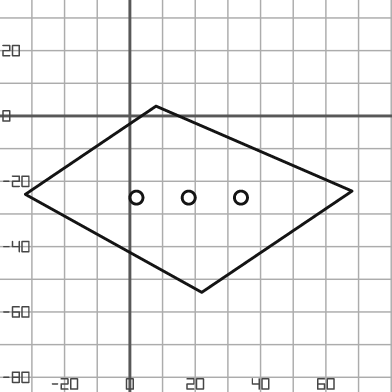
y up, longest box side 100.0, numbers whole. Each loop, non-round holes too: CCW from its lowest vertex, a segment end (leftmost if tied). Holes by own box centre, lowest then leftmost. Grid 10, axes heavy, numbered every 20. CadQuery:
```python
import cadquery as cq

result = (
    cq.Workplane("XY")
    .moveTo(22.0, -54.0)
    .lineTo(68.0, -23.0)
    .lineTo(8.0, 3.0)
    .lineTo(-32.0, -24.0)
    .close()
    .moveTo(2.0, -25.0)
    .circle(2.0)
    .moveTo(18.0, -25.0)
    .circle(2.0)
    .moveTo(34.0, -25.0)
    .circle(2.0)
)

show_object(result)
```